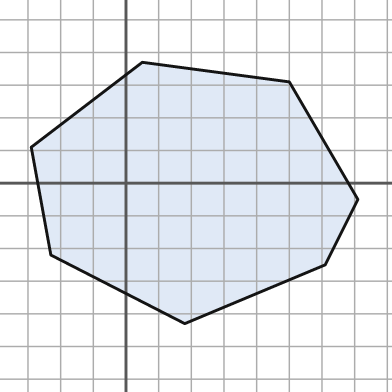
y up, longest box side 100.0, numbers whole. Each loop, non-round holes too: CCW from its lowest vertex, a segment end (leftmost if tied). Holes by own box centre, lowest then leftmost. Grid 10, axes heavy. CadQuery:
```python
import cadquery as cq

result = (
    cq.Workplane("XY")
    .moveTo(18.0, -43.0)
    .lineTo(61.0, -25.0)
    .lineTo(71.0, -5.0)
    .lineTo(50.0, 31.0)
    .lineTo(5.0, 37.0)
    .lineTo(-29.0, 11.0)
    .lineTo(-23.0, -22.0)
    .close()
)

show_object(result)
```